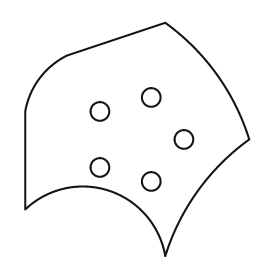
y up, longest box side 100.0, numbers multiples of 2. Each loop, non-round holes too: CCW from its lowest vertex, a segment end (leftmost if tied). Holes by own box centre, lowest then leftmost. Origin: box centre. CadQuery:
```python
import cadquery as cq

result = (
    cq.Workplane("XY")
    .moveTo(12.0, -50.0)
    .threePointArc((26.0, -22.0), (48.0, 0.0))
    .threePointArc((34.0, 28.0), (12.0, 50.0))
    .lineTo(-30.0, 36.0)
    .threePointArc((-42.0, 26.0), (-48.0, 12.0))
    .lineTo(-48.0, -30.0)
    .threePointArc((-12.0, -22.0), (12.0, -50.0))
    .close()
    .moveTo(6.0, -18.0)
    .circle(4.0)
    .moveTo(-16.0, -12.0)
    .circle(4.0)
    .moveTo(20.0, 0.0)
    .circle(4.0)
    .moveTo(-16.0, 12.0)
    .circle(4.0)
    .moveTo(6.0, 18.0)
    .circle(4.0)
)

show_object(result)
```